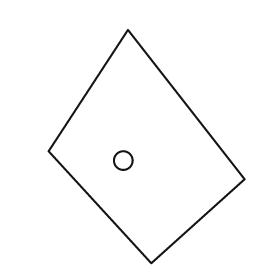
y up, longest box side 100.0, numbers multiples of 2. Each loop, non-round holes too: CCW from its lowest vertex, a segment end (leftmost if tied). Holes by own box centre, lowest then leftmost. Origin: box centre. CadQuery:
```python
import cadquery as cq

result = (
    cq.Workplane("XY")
    .moveTo(2.0, -50.0)
    .lineTo(42.0, -14.0)
    .lineTo(-8.0, 50.0)
    .lineTo(-42.0, -2.0)
    .close()
    .moveTo(-10.0, -6.0)
    .circle(4.0)
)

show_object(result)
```